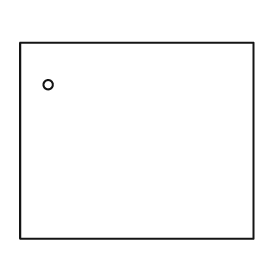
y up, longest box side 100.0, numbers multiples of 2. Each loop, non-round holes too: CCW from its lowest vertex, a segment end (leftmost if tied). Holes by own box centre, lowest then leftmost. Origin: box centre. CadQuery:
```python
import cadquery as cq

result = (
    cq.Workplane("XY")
    .moveTo(-50.0, -42.0)
    .lineTo(50.0, -42.0)
    .lineTo(50.0, 42.0)
    .lineTo(-50.0, 42.0)
    .close()
    .moveTo(-38.0, 24.0)
    .circle(2.0)
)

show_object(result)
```